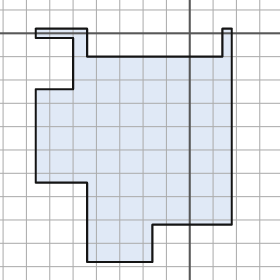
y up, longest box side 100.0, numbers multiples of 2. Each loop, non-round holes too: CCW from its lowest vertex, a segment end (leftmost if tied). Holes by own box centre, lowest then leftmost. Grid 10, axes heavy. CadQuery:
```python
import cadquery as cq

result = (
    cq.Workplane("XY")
    .moveTo(-44.0, -98.0)
    .lineTo(-16.0, -98.0)
    .lineTo(-16.0, -82.0)
    .lineTo(18.0, -82.0)
    .lineTo(18.0, 2.0)
    .lineTo(14.0, 2.0)
    .lineTo(14.0, -10.0)
    .lineTo(-44.0, -10.0)
    .lineTo(-44.0, 2.0)
    .lineTo(-66.0, 2.0)
    .lineTo(-66.0, -2.0)
    .lineTo(-50.0, -2.0)
    .lineTo(-50.0, -24.0)
    .lineTo(-66.0, -24.0)
    .lineTo(-66.0, -64.0)
    .lineTo(-44.0, -64.0)
    .close()
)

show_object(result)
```